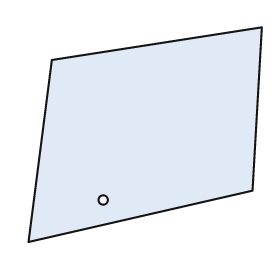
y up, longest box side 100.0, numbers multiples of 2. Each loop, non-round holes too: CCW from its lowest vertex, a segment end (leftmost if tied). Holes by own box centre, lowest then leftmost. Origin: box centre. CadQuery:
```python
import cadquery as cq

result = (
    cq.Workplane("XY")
    .moveTo(-50.0, -46.0)
    .lineTo(46.0, -24.0)
    .lineTo(50.0, 46.0)
    .lineTo(-40.0, 32.0)
    .close()
    .moveTo(-18.0, -28.0)
    .circle(2.0)
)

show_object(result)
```